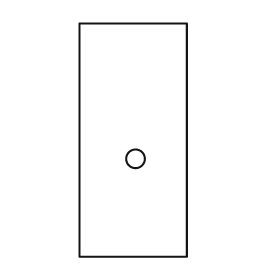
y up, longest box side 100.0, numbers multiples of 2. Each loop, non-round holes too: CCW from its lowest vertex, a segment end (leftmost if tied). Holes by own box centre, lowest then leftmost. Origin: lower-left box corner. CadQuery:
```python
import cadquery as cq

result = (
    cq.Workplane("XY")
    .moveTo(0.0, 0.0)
    .lineTo(46.0, 0.0)
    .lineTo(46.0, 100.0)
    .lineTo(0.0, 100.0)
    .close()
    .moveTo(24.0, 42.0)
    .circle(4.0)
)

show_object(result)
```